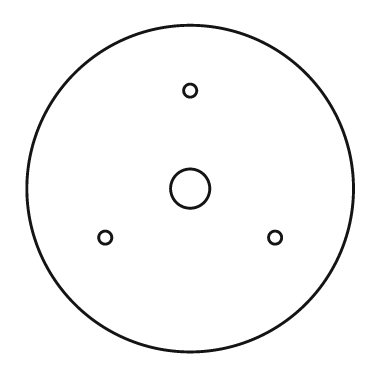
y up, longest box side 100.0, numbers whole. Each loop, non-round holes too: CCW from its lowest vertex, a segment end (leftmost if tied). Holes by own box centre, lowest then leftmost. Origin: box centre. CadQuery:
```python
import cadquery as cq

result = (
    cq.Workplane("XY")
    .moveTo(0.0, 0.0)
    .circle(50.0)
    .moveTo(-26.0, -15.0)
    .circle(2.0)
    .moveTo(26.0, -15.0)
    .circle(2.0)
    .moveTo(0.0, 0.0)
    .circle(6.0)
    .moveTo(0.0, 30.0)
    .circle(2.0)
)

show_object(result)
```